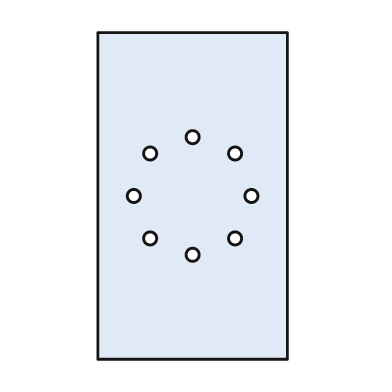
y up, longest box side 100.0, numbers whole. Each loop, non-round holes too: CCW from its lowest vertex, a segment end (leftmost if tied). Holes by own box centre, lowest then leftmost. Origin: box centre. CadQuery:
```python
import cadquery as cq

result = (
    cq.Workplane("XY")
    .moveTo(-29.0, -50.0)
    .lineTo(29.0, -50.0)
    .lineTo(29.0, 50.0)
    .lineTo(-29.0, 50.0)
    .close()
    .moveTo(0.0, -18.0)
    .circle(2.0)
    .moveTo(-13.0, -13.0)
    .circle(2.0)
    .moveTo(13.0, -13.0)
    .circle(2.0)
    .moveTo(-18.0, 0.0)
    .circle(2.0)
    .moveTo(18.0, 0.0)
    .circle(2.0)
    .moveTo(-13.0, 13.0)
    .circle(2.0)
    .moveTo(13.0, 13.0)
    .circle(2.0)
    .moveTo(0.0, 18.0)
    .circle(2.0)
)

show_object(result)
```